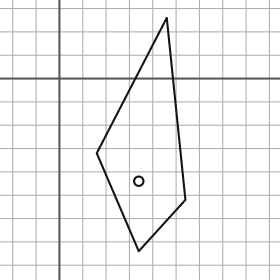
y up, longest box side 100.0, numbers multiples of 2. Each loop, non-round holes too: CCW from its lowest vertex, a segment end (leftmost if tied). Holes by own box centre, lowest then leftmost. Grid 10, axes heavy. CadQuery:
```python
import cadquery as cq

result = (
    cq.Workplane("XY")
    .moveTo(34.0, -74.0)
    .lineTo(54.0, -52.0)
    .lineTo(46.0, 26.0)
    .lineTo(16.0, -32.0)
    .close()
    .moveTo(34.0, -44.0)
    .circle(2.0)
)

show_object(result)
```